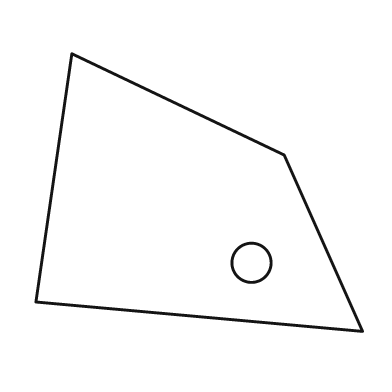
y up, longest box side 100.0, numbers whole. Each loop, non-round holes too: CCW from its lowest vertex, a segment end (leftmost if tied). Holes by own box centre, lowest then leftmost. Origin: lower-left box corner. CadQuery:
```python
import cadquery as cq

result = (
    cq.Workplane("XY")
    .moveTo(100.0, 0.0)
    .lineTo(76.0, 54.0)
    .lineTo(11.0, 85.0)
    .lineTo(0.0, 9.0)
    .close()
    .moveTo(66.0, 21.0)
    .circle(6.0)
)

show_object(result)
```